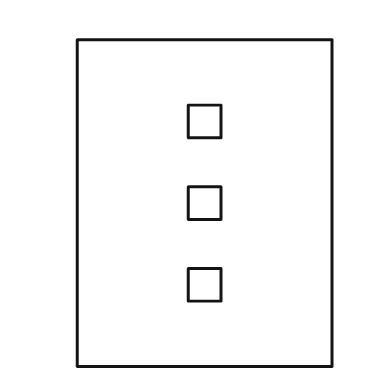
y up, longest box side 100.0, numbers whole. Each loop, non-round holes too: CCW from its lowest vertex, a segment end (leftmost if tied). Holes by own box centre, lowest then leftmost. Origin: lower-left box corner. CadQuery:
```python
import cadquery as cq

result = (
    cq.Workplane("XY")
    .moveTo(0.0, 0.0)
    .lineTo(78.0, 0.0)
    .lineTo(78.0, 100.0)
    .lineTo(0.0, 100.0)
    .close()
    .moveTo(34.0, 20.0)
    .lineTo(44.0, 20.0)
    .lineTo(44.0, 30.0)
    .lineTo(34.0, 30.0)
    .close()
    .moveTo(34.0, 45.0)
    .lineTo(44.0, 45.0)
    .lineTo(44.0, 55.0)
    .lineTo(34.0, 55.0)
    .close()
    .moveTo(34.0, 70.0)
    .lineTo(44.0, 70.0)
    .lineTo(44.0, 80.0)
    .lineTo(34.0, 80.0)
    .close()
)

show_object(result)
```